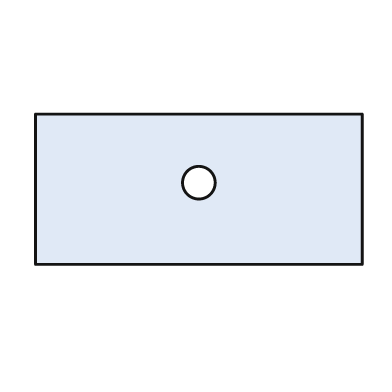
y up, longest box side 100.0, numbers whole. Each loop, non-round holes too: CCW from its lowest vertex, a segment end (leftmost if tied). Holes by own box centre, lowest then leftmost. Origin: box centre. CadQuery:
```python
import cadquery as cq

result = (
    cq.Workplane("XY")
    .moveTo(-50.0, -23.0)
    .lineTo(50.0, -23.0)
    .lineTo(50.0, 23.0)
    .lineTo(-50.0, 23.0)
    .close()
    .moveTo(0.0, 2.0)
    .circle(5.0)
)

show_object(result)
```